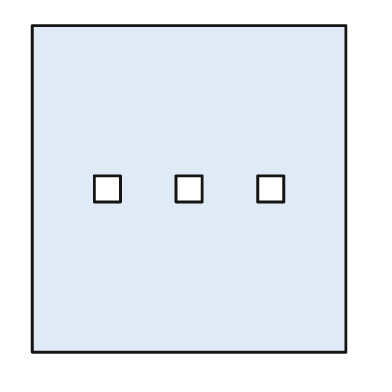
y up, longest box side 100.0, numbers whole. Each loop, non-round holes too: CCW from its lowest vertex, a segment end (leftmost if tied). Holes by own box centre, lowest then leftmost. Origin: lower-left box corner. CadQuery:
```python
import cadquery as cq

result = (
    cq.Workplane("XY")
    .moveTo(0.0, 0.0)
    .lineTo(96.0, 0.0)
    .lineTo(96.0, 100.0)
    .lineTo(0.0, 100.0)
    .close()
    .moveTo(19.0, 46.0)
    .lineTo(27.0, 46.0)
    .lineTo(27.0, 54.0)
    .lineTo(19.0, 54.0)
    .close()
    .moveTo(44.0, 46.0)
    .lineTo(52.0, 46.0)
    .lineTo(52.0, 54.0)
    .lineTo(44.0, 54.0)
    .close()
    .moveTo(69.0, 46.0)
    .lineTo(77.0, 46.0)
    .lineTo(77.0, 54.0)
    .lineTo(69.0, 54.0)
    .close()
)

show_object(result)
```